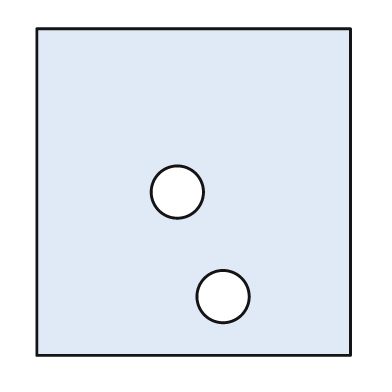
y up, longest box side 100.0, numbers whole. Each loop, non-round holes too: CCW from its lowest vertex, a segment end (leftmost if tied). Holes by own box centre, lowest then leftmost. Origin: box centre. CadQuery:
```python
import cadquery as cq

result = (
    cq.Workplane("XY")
    .moveTo(-48.0, -50.0)
    .lineTo(48.0, -50.0)
    .lineTo(48.0, 50.0)
    .lineTo(-48.0, 50.0)
    .close()
    .moveTo(9.0, -32.0)
    .circle(8.0)
    .moveTo(-5.0, 0.0)
    .circle(8.0)
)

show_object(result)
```